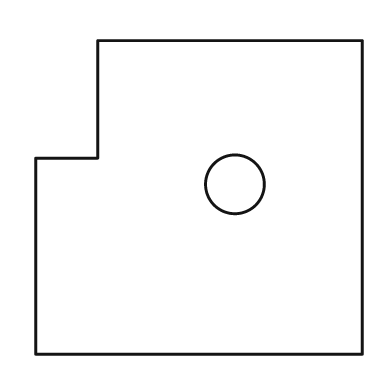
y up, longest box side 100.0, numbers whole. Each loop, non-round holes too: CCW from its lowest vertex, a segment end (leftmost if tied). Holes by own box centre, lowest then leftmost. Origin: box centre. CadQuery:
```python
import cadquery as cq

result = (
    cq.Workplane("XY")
    .moveTo(-50.0, -48.0)
    .lineTo(50.0, -48.0)
    .lineTo(50.0, 48.0)
    .lineTo(-31.0, 48.0)
    .lineTo(-31.0, 12.0)
    .lineTo(-50.0, 12.0)
    .close()
    .moveTo(11.0, 4.0)
    .circle(9.0)
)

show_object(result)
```